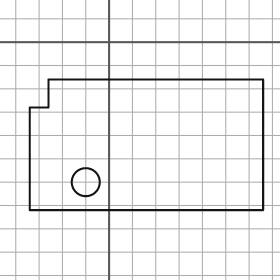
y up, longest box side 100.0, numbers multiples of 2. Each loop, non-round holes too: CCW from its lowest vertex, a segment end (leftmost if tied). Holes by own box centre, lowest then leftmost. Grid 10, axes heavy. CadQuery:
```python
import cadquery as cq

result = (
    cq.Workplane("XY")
    .moveTo(-34.0, -72.0)
    .lineTo(66.0, -72.0)
    .lineTo(66.0, -16.0)
    .lineTo(-26.0, -16.0)
    .lineTo(-26.0, -28.0)
    .lineTo(-34.0, -28.0)
    .close()
    .moveTo(-10.0, -60.0)
    .circle(6.0)
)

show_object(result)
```